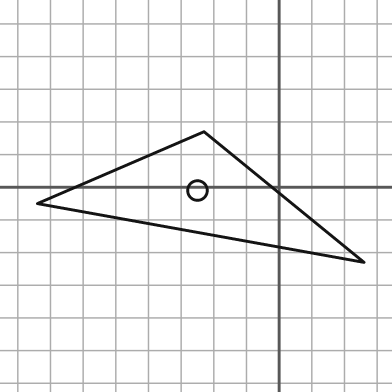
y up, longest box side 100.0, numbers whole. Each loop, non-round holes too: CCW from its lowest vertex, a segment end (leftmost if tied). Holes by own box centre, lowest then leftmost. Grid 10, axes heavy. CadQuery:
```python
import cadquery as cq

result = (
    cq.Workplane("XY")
    .moveTo(26.0, -23.0)
    .lineTo(-23.0, 17.0)
    .lineTo(-74.0, -5.0)
    .close()
    .moveTo(-25.0, -1.0)
    .circle(3.0)
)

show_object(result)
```